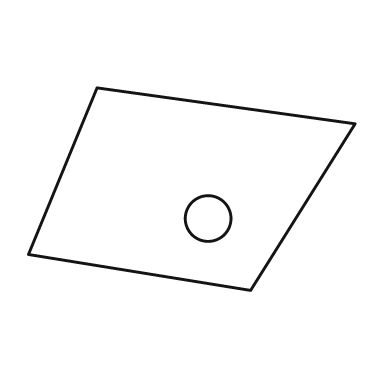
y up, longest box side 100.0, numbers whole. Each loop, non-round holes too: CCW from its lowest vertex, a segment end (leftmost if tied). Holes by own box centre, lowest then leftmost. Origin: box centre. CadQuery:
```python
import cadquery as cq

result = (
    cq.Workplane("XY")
    .moveTo(18.0, -31.0)
    .lineTo(50.0, 20.0)
    .lineTo(-29.0, 31.0)
    .lineTo(-50.0, -20.0)
    .close()
    .moveTo(5.0, -9.0)
    .circle(7.0)
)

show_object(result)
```